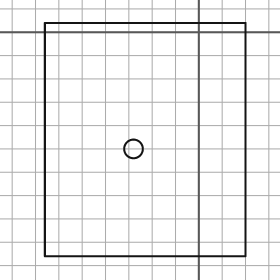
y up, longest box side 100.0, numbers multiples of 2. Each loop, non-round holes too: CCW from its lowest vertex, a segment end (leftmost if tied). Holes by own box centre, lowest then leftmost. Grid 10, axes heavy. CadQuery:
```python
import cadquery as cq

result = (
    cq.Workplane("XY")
    .moveTo(-66.0, -96.0)
    .lineTo(20.0, -96.0)
    .lineTo(20.0, 4.0)
    .lineTo(-66.0, 4.0)
    .close()
    .moveTo(-28.0, -50.0)
    .circle(4.0)
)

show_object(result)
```